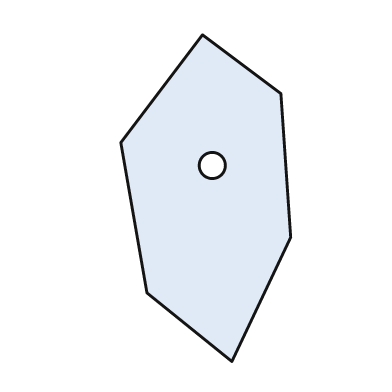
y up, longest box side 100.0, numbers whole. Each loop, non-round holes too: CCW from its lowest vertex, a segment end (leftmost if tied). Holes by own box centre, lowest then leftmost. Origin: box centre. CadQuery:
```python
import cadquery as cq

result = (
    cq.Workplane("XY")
    .moveTo(8.0, -50.0)
    .lineTo(26.0, -12.0)
    .lineTo(23.0, 32.0)
    .lineTo(-1.0, 50.0)
    .lineTo(-26.0, 17.0)
    .lineTo(-18.0, -29.0)
    .close()
    .moveTo(2.0, 10.0)
    .circle(4.0)
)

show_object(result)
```